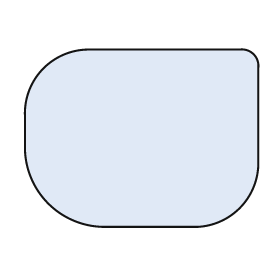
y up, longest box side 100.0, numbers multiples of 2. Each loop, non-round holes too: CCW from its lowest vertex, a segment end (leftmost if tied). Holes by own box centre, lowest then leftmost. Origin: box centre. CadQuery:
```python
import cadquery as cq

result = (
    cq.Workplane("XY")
    .moveTo(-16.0, -38.0)
    .lineTo(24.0, -38.0)
    .threePointArc((42.0, -30.0), (50.0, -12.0))
    .lineTo(50.0, 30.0)
    .threePointArc((48.0, 36.0), (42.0, 38.0))
    .lineTo(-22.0, 38.0)
    .threePointArc((-42.0, 30.0), (-50.0, 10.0))
    .lineTo(-50.0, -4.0)
    .threePointArc((-40.0, -28.0), (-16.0, -38.0))
    .close()
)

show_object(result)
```